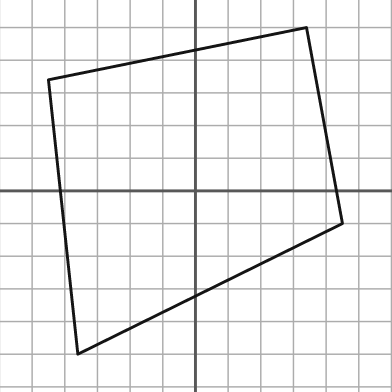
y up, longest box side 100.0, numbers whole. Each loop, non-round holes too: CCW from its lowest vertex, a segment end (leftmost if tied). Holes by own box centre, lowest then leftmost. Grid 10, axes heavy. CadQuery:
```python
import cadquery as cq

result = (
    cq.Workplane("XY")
    .moveTo(-36.0, -50.0)
    .lineTo(45.0, -10.0)
    .lineTo(34.0, 50.0)
    .lineTo(-45.0, 34.0)
    .close()
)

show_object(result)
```